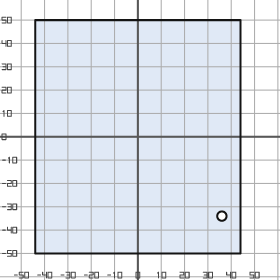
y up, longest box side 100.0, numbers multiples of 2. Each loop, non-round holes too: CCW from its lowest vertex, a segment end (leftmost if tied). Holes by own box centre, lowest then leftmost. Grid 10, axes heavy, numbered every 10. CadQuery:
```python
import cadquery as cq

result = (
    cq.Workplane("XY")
    .moveTo(-44.0, -50.0)
    .lineTo(44.0, -50.0)
    .lineTo(44.0, 50.0)
    .lineTo(-44.0, 50.0)
    .close()
    .moveTo(36.0, -34.0)
    .circle(2.0)
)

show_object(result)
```